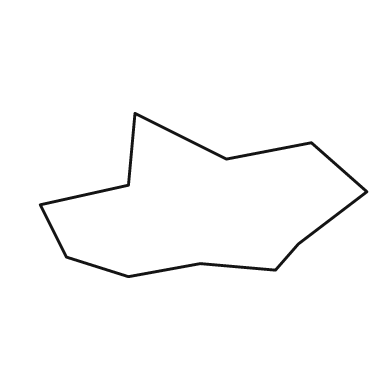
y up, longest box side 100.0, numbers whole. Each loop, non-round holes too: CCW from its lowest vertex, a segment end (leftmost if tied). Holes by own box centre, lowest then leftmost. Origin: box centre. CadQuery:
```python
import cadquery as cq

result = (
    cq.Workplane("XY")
    .moveTo(-23.0, -25.0)
    .lineTo(-1.0, -21.0)
    .lineTo(22.0, -23.0)
    .lineTo(29.0, -15.0)
    .lineTo(50.0, 1.0)
    .lineTo(33.0, 16.0)
    .lineTo(7.0, 11.0)
    .lineTo(-21.0, 25.0)
    .lineTo(-23.0, 3.0)
    .lineTo(-50.0, -3.0)
    .lineTo(-42.0, -19.0)
    .close()
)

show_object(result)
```